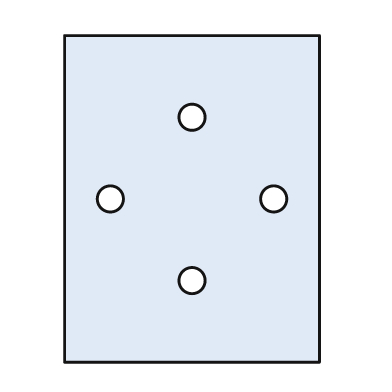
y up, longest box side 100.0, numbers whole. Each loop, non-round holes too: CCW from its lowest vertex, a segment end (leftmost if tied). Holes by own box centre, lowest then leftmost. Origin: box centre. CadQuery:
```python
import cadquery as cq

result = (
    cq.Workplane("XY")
    .moveTo(-39.0, -50.0)
    .lineTo(39.0, -50.0)
    .lineTo(39.0, 50.0)
    .lineTo(-39.0, 50.0)
    .close()
    .moveTo(0.0, -25.0)
    .circle(4.0)
    .moveTo(-25.0, 0.0)
    .circle(4.0)
    .moveTo(25.0, 0.0)
    .circle(4.0)
    .moveTo(0.0, 25.0)
    .circle(4.0)
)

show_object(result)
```